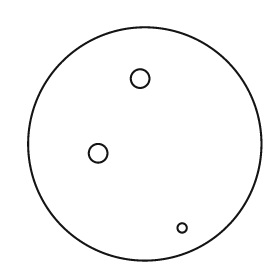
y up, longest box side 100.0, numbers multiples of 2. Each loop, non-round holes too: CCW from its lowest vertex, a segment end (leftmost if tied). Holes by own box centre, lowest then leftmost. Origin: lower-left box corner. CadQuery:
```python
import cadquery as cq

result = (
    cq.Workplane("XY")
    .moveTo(50.0, 50.0)
    .circle(50.0)
    .moveTo(66.0, 14.0)
    .circle(2.0)
    .moveTo(30.0, 46.0)
    .circle(4.0)
    .moveTo(48.0, 78.0)
    .circle(4.0)
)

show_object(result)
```